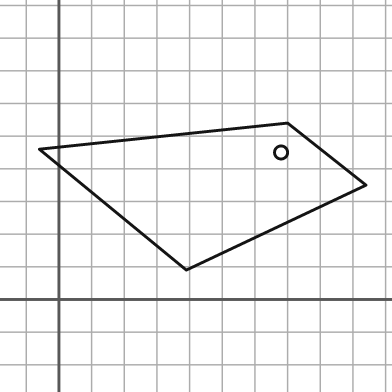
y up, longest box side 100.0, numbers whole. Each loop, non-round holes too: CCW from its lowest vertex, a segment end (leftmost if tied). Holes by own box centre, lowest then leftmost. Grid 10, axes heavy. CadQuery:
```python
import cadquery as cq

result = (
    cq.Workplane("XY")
    .moveTo(39.0, 9.0)
    .lineTo(94.0, 35.0)
    .lineTo(70.0, 54.0)
    .lineTo(-6.0, 46.0)
    .close()
    .moveTo(68.0, 45.0)
    .circle(2.0)
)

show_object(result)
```